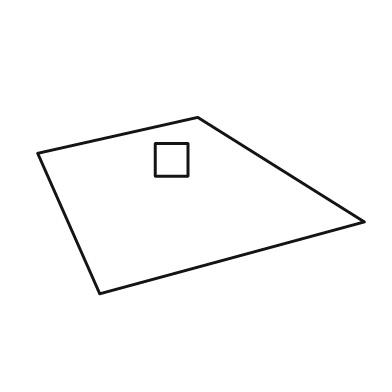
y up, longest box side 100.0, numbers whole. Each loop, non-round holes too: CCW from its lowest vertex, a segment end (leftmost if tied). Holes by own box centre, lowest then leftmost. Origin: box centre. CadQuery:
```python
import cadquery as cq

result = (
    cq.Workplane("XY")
    .moveTo(-31.0, -27.0)
    .lineTo(50.0, -5.0)
    .lineTo(-1.0, 27.0)
    .lineTo(-50.0, 16.0)
    .close()
    .moveTo(-14.0, 9.0)
    .lineTo(-4.0, 9.0)
    .lineTo(-4.0, 19.0)
    .lineTo(-14.0, 19.0)
    .close()
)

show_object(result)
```